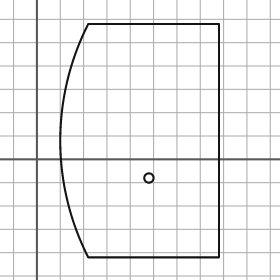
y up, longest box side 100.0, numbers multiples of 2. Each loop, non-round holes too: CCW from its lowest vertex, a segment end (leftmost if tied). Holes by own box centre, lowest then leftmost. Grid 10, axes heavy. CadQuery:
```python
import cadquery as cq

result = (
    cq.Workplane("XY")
    .moveTo(22.0, -42.0)
    .lineTo(78.0, -42.0)
    .lineTo(78.0, 58.0)
    .lineTo(22.0, 58.0)
    .threePointArc((10.0, 8.0), (22.0, -42.0))
    .close()
    .moveTo(48.0, -8.0)
    .circle(2.0)
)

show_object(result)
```